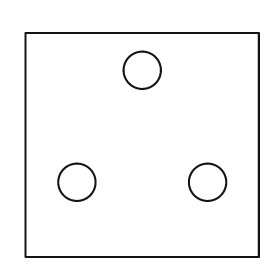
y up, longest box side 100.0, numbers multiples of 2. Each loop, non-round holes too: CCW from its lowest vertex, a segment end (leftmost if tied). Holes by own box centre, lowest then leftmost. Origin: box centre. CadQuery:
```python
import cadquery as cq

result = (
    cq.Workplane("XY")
    .moveTo(-50.0, -48.0)
    .lineTo(50.0, -48.0)
    .lineTo(50.0, 48.0)
    .lineTo(-50.0, 48.0)
    .close()
    .moveTo(-28.0, -16.0)
    .circle(8.0)
    .moveTo(28.0, -16.0)
    .circle(8.0)
    .moveTo(0.0, 32.0)
    .circle(8.0)
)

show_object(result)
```